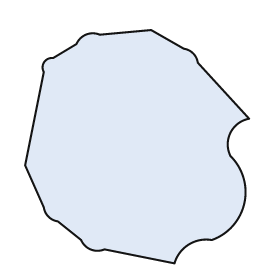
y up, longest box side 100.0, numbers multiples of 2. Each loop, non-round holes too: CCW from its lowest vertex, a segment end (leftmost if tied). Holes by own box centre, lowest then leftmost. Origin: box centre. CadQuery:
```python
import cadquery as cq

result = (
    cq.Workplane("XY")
    .moveTo(16.0, -50.0)
    .threePointArc((22.0, -42.0), (32.0, -40.0))
    .threePointArc((46.0, -24.0), (40.0, -4.0))
    .threePointArc((40.0, 6.0), (48.0, 12.0))
    .lineTo(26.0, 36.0)
    .threePointArc((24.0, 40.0), (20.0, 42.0))
    .lineTo(6.0, 50.0)
    .lineTo(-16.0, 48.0)
    .threePointArc((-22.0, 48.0), (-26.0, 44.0))
    .lineTo(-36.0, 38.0)
    .threePointArc((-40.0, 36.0), (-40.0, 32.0))
    .lineTo(-48.0, -8.0)
    .lineTo(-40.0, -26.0)
    .threePointArc((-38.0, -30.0), (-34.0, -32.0))
    .lineTo(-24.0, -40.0)
    .threePointArc((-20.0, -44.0), (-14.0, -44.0))
    .close()
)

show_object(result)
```